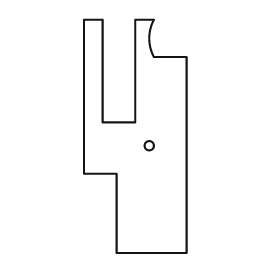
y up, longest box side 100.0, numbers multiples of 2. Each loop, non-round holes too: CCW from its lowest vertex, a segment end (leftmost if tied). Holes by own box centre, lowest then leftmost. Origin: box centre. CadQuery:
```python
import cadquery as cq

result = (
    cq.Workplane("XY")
    .moveTo(-8.0, -50.0)
    .lineTo(22.0, -50.0)
    .lineTo(22.0, 34.0)
    .lineTo(8.0, 34.0)
    .threePointArc((6.0, 42.0), (8.0, 50.0))
    .lineTo(0.0, 50.0)
    .lineTo(0.0, 6.0)
    .lineTo(-14.0, 6.0)
    .lineTo(-14.0, 50.0)
    .lineTo(-22.0, 50.0)
    .lineTo(-22.0, -16.0)
    .lineTo(-8.0, -16.0)
    .close()
    .moveTo(6.0, -4.0)
    .circle(2.0)
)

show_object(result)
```